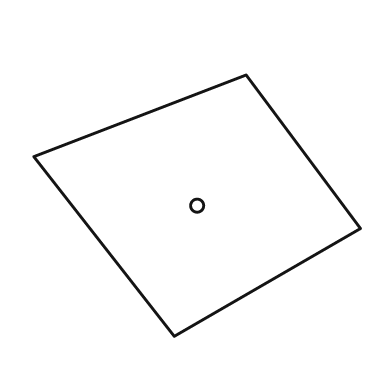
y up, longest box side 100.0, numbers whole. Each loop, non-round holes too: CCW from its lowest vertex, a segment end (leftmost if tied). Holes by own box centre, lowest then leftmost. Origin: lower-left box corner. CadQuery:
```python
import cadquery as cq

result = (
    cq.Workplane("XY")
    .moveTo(43.0, 0.0)
    .lineTo(100.0, 33.0)
    .lineTo(65.0, 80.0)
    .lineTo(0.0, 55.0)
    .close()
    .moveTo(50.0, 40.0)
    .circle(2.0)
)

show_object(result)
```